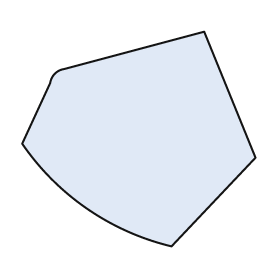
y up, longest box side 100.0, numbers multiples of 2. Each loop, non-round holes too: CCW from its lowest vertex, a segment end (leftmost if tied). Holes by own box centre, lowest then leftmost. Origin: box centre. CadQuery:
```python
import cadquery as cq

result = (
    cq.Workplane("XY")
    .moveTo(14.0, -46.0)
    .lineTo(50.0, -8.0)
    .lineTo(28.0, 46.0)
    .lineTo(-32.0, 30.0)
    .threePointArc((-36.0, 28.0), (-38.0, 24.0))
    .lineTo(-50.0, -2.0)
    .threePointArc((-22.0, -30.0), (14.0, -46.0))
    .close()
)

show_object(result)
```